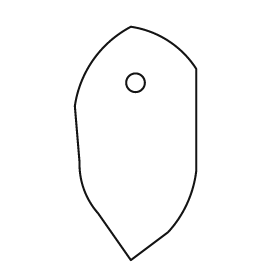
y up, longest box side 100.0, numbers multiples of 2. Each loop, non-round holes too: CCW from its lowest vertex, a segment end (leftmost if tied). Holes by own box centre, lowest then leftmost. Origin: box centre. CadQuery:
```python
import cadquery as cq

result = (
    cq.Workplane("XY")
    .moveTo(-2.0, -50.0)
    .lineTo(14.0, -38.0)
    .threePointArc((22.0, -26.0), (26.0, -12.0))
    .lineTo(26.0, 32.0)
    .threePointArc((14.0, 44.0), (-2.0, 50.0))
    .threePointArc((-18.0, 36.0), (-26.0, 16.0))
    .lineTo(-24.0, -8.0)
    .threePointArc((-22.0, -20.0), (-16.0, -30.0))
    .close()
    .moveTo(0.0, 26.0)
    .circle(4.0)
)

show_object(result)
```